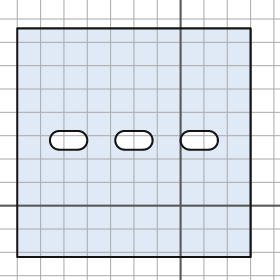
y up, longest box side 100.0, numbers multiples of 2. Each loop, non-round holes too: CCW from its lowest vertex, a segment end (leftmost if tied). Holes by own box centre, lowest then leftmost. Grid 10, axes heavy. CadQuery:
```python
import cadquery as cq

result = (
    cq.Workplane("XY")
    .moveTo(-70.0, -22.0)
    .lineTo(30.0, -22.0)
    .lineTo(30.0, 76.0)
    .lineTo(-70.0, 76.0)
    .close()
    .moveTo(-52.0, 24.0)
    .lineTo(-44.0, 24.0)
    .threePointArc((-40.0, 28.0), (-44.0, 32.0))
    .lineTo(-52.0, 32.0)
    .threePointArc((-56.0, 28.0), (-52.0, 24.0))
    .close()
    .moveTo(-24.0, 24.0)
    .lineTo(-16.0, 24.0)
    .threePointArc((-12.0, 28.0), (-16.0, 32.0))
    .lineTo(-24.0, 32.0)
    .threePointArc((-28.0, 28.0), (-24.0, 24.0))
    .close()
    .moveTo(4.0, 24.0)
    .lineTo(12.0, 24.0)
    .threePointArc((16.0, 28.0), (12.0, 32.0))
    .lineTo(4.0, 32.0)
    .threePointArc((0.0, 28.0), (4.0, 24.0))
    .close()
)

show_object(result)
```